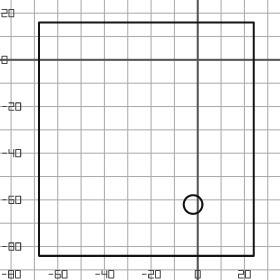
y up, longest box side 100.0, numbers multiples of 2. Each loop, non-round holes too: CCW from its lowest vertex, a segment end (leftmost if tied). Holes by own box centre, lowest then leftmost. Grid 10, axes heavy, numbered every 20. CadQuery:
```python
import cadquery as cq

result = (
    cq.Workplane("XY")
    .moveTo(-68.0, -84.0)
    .lineTo(24.0, -84.0)
    .lineTo(24.0, 16.0)
    .lineTo(-68.0, 16.0)
    .close()
    .moveTo(-2.0, -62.0)
    .circle(4.0)
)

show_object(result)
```